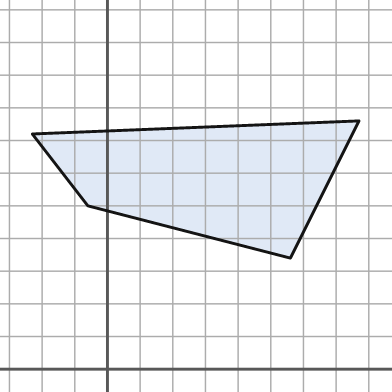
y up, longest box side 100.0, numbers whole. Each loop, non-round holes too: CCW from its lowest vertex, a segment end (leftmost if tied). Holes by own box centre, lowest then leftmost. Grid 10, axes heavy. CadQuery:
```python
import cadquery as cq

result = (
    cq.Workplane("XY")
    .moveTo(56.0, 34.0)
    .lineTo(77.0, 76.0)
    .lineTo(-23.0, 72.0)
    .lineTo(-6.0, 50.0)
    .close()
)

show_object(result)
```